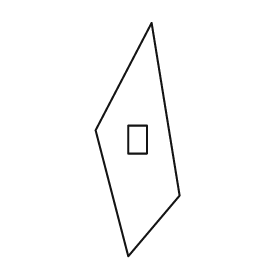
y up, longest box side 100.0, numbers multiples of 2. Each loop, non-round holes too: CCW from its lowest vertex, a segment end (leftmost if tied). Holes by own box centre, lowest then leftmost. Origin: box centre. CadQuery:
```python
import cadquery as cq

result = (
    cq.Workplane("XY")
    .moveTo(-4.0, -50.0)
    .lineTo(18.0, -24.0)
    .lineTo(6.0, 50.0)
    .lineTo(-18.0, 4.0)
    .close()
    .moveTo(-4.0, -6.0)
    .lineTo(4.0, -6.0)
    .lineTo(4.0, 6.0)
    .lineTo(-4.0, 6.0)
    .close()
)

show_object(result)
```